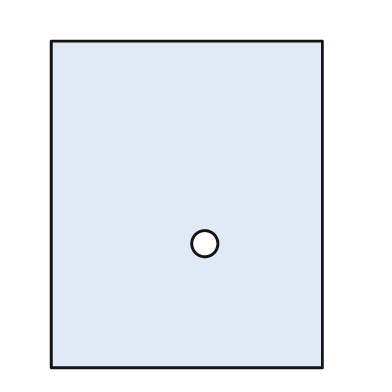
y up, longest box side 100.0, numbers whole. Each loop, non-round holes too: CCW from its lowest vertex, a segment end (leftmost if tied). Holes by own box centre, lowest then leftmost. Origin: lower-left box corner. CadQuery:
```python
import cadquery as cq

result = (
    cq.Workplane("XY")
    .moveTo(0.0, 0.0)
    .lineTo(83.0, 0.0)
    .lineTo(83.0, 100.0)
    .lineTo(0.0, 100.0)
    .close()
    .moveTo(47.0, 38.0)
    .circle(4.0)
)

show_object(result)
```